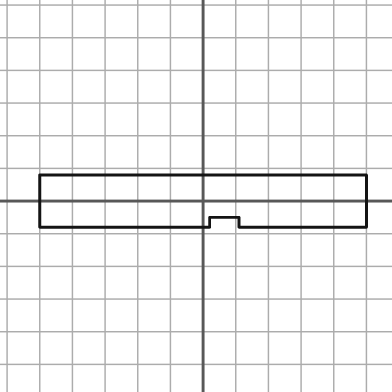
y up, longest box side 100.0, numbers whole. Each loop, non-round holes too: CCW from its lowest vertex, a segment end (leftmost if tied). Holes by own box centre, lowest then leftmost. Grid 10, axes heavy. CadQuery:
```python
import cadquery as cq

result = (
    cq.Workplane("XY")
    .moveTo(-50.0, -8.0)
    .lineTo(2.0, -8.0)
    .lineTo(2.0, -5.0)
    .lineTo(11.0, -5.0)
    .lineTo(11.0, -8.0)
    .lineTo(50.0, -8.0)
    .lineTo(50.0, 8.0)
    .lineTo(-50.0, 8.0)
    .close()
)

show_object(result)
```